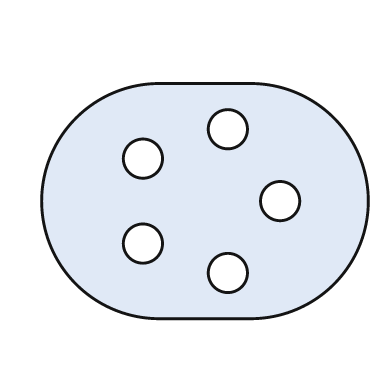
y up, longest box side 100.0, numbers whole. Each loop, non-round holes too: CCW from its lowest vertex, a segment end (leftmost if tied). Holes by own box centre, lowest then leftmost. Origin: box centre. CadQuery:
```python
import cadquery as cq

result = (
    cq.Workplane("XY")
    .moveTo(-14.0, -36.0)
    .lineTo(14.0, -36.0)
    .threePointArc((50.0, 0.0), (14.0, 36.0))
    .lineTo(-14.0, 36.0)
    .threePointArc((-50.0, 0.0), (-14.0, -36.0))
    .close()
    .moveTo(7.0, -22.0)
    .circle(6.0)
    .moveTo(-19.0, -13.0)
    .circle(6.0)
    .moveTo(23.0, 0.0)
    .circle(6.0)
    .moveTo(-19.0, 13.0)
    .circle(6.0)
    .moveTo(7.0, 22.0)
    .circle(6.0)
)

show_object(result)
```